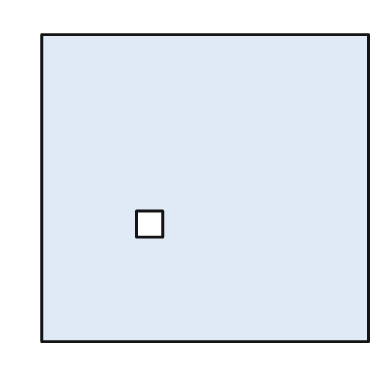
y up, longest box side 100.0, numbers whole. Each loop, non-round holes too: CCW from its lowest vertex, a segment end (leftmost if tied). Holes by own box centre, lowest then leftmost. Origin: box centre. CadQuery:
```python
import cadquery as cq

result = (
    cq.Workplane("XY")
    .moveTo(-50.0, -47.0)
    .lineTo(50.0, -47.0)
    .lineTo(50.0, 47.0)
    .lineTo(-50.0, 47.0)
    .close()
    .moveTo(-21.0, -15.0)
    .lineTo(-13.0, -15.0)
    .lineTo(-13.0, -7.0)
    .lineTo(-21.0, -7.0)
    .close()
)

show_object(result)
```